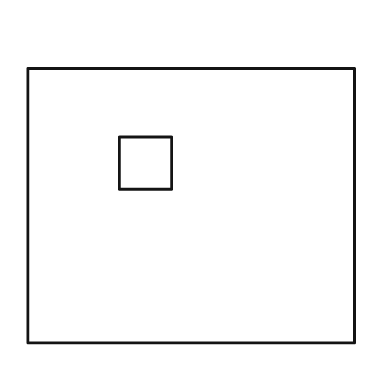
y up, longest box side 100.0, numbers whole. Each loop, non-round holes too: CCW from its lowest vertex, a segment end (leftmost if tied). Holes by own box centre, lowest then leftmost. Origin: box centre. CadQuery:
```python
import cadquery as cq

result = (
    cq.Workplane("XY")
    .moveTo(-50.0, -42.0)
    .lineTo(50.0, -42.0)
    .lineTo(50.0, 42.0)
    .lineTo(-50.0, 42.0)
    .close()
    .moveTo(-22.0, 5.0)
    .lineTo(-6.0, 5.0)
    .lineTo(-6.0, 21.0)
    .lineTo(-22.0, 21.0)
    .close()
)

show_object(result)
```